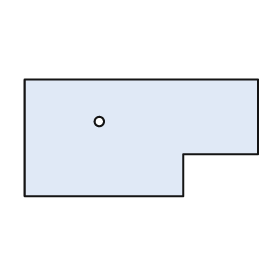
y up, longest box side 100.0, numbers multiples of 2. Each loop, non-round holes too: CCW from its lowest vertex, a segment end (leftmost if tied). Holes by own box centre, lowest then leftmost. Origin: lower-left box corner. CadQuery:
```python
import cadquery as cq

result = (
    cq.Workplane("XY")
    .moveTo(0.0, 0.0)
    .lineTo(68.0, 0.0)
    .lineTo(68.0, 18.0)
    .lineTo(100.0, 18.0)
    .lineTo(100.0, 50.0)
    .lineTo(0.0, 50.0)
    .close()
    .moveTo(32.0, 32.0)
    .circle(2.0)
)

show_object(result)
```